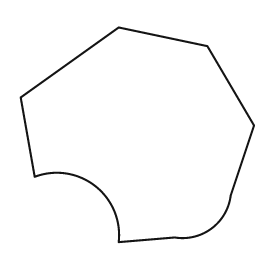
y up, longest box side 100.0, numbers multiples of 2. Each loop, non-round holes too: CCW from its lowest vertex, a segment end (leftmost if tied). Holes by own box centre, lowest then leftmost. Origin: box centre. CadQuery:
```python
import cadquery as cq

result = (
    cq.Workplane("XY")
    .moveTo(-8.0, -46.0)
    .lineTo(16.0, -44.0)
    .threePointArc((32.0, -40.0), (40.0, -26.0))
    .lineTo(50.0, 4.0)
    .lineTo(30.0, 38.0)
    .lineTo(-8.0, 46.0)
    .lineTo(-50.0, 16.0)
    .lineTo(-44.0, -18.0)
    .threePointArc((-18.0, -22.0), (-8.0, -46.0))
    .close()
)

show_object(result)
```